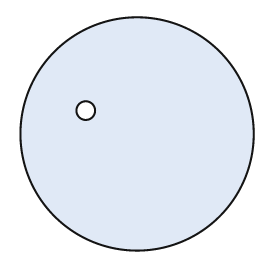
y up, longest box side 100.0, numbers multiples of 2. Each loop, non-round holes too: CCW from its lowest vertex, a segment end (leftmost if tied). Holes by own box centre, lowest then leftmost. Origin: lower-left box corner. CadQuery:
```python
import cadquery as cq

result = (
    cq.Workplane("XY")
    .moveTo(50.0, 50.0)
    .circle(50.0)
    .moveTo(28.0, 60.0)
    .circle(4.0)
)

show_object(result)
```